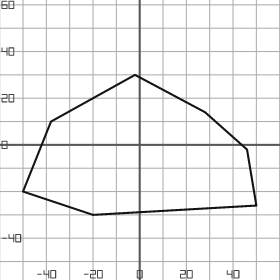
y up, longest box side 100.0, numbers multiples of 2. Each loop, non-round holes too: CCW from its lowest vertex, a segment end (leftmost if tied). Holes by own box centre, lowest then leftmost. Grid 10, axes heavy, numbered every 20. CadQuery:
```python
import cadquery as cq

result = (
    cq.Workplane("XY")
    .moveTo(-20.0, -30.0)
    .lineTo(50.0, -26.0)
    .lineTo(46.0, -2.0)
    .lineTo(28.0, 14.0)
    .lineTo(-2.0, 30.0)
    .lineTo(-38.0, 10.0)
    .lineTo(-50.0, -20.0)
    .close()
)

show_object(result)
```